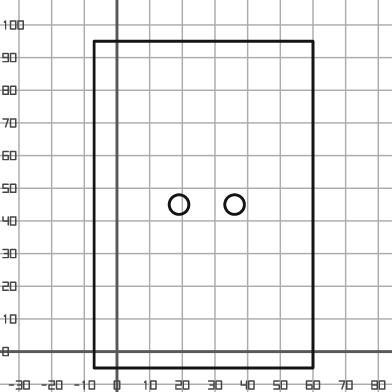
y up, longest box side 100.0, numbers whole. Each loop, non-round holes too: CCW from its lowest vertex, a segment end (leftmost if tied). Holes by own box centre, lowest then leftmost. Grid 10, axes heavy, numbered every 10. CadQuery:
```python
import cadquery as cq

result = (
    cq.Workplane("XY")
    .moveTo(-7.0, -5.0)
    .lineTo(60.0, -5.0)
    .lineTo(60.0, 95.0)
    .lineTo(-7.0, 95.0)
    .close()
    .moveTo(19.0, 45.0)
    .circle(3.0)
    .moveTo(36.0, 45.0)
    .circle(3.0)
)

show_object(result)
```